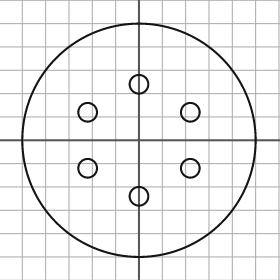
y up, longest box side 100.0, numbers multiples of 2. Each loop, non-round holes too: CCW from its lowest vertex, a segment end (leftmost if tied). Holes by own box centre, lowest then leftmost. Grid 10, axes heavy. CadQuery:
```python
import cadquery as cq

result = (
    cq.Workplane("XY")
    .moveTo(0.0, 0.0)
    .circle(50.0)
    .moveTo(0.0, -24.0)
    .circle(4.0)
    .moveTo(-22.0, -12.0)
    .circle(4.0)
    .moveTo(22.0, -12.0)
    .circle(4.0)
    .moveTo(-22.0, 12.0)
    .circle(4.0)
    .moveTo(22.0, 12.0)
    .circle(4.0)
    .moveTo(0.0, 24.0)
    .circle(4.0)
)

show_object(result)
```